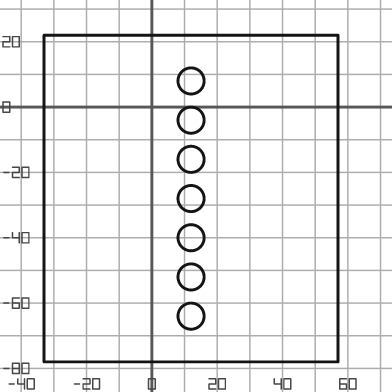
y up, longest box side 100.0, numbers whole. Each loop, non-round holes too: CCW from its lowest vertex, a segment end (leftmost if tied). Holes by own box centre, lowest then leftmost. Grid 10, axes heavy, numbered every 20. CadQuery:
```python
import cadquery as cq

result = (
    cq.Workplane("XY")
    .moveTo(-33.0, -78.0)
    .lineTo(57.0, -78.0)
    .lineTo(57.0, 22.0)
    .lineTo(-33.0, 22.0)
    .close()
    .moveTo(12.0, -64.0)
    .circle(4.0)
    .moveTo(12.0, -52.0)
    .circle(4.0)
    .moveTo(12.0, -40.0)
    .circle(4.0)
    .moveTo(12.0, -28.0)
    .circle(4.0)
    .moveTo(12.0, -16.0)
    .circle(4.0)
    .moveTo(12.0, -4.0)
    .circle(4.0)
    .moveTo(12.0, 8.0)
    .circle(4.0)
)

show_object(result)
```